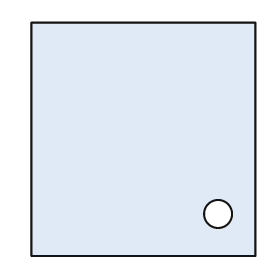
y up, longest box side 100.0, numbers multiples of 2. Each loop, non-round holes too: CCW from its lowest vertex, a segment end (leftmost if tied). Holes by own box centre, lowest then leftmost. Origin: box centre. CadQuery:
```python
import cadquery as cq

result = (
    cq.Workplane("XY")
    .moveTo(-48.0, -50.0)
    .lineTo(48.0, -50.0)
    .lineTo(48.0, 50.0)
    .lineTo(-48.0, 50.0)
    .close()
    .moveTo(32.0, -32.0)
    .circle(6.0)
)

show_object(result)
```